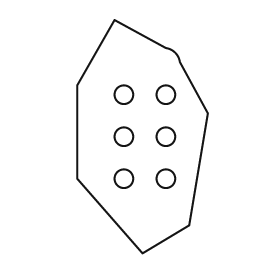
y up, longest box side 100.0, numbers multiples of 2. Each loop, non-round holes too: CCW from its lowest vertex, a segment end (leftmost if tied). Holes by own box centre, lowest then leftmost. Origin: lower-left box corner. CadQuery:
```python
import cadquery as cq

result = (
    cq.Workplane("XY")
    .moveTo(28.0, 0.0)
    .lineTo(48.0, 12.0)
    .lineTo(56.0, 60.0)
    .lineTo(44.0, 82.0)
    .threePointArc((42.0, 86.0), (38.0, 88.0))
    .lineTo(16.0, 100.0)
    .lineTo(0.0, 72.0)
    .lineTo(0.0, 32.0)
    .close()
    .moveTo(20.0, 32.0)
    .circle(4.0)
    .moveTo(38.0, 32.0)
    .circle(4.0)
    .moveTo(20.0, 50.0)
    .circle(4.0)
    .moveTo(38.0, 50.0)
    .circle(4.0)
    .moveTo(20.0, 68.0)
    .circle(4.0)
    .moveTo(38.0, 68.0)
    .circle(4.0)
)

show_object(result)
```